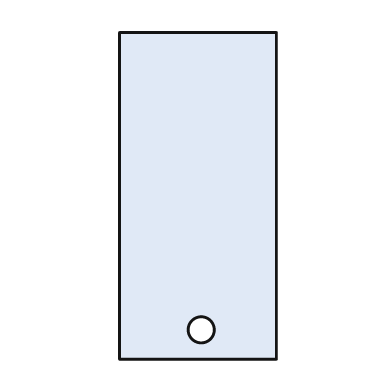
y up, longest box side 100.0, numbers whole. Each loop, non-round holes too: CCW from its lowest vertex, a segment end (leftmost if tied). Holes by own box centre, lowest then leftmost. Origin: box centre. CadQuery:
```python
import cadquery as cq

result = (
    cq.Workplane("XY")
    .moveTo(-24.0, -50.0)
    .lineTo(24.0, -50.0)
    .lineTo(24.0, 50.0)
    .lineTo(-24.0, 50.0)
    .close()
    .moveTo(1.0, -41.0)
    .circle(4.0)
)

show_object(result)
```